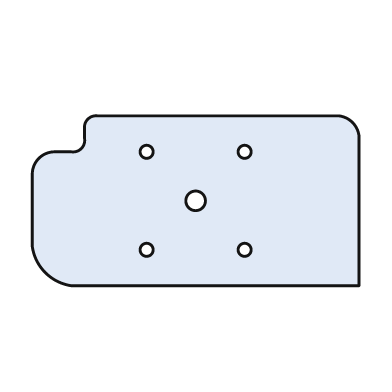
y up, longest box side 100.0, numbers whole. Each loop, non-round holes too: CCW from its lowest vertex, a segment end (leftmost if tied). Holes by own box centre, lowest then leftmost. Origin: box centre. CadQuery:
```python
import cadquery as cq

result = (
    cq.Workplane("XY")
    .moveTo(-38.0, -26.0)
    .lineTo(50.0, -26.0)
    .lineTo(50.0, 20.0)
    .threePointArc((48.0, 24.0), (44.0, 26.0))
    .lineTo(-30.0, 26.0)
    .threePointArc((-33.0, 25.0), (-34.0, 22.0))
    .lineTo(-34.0, 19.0)
    .threePointArc((-35.0, 16.0), (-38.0, 15.0))
    .lineTo(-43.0, 15.0)
    .threePointArc((-48.0, 13.0), (-50.0, 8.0))
    .lineTo(-50.0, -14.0)
    .threePointArc((-46.0, -22.0), (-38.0, -26.0))
    .close()
    .moveTo(-15.0, -15.0)
    .circle(2.0)
    .moveTo(15.0, -15.0)
    .circle(2.0)
    .moveTo(0.0, 0.0)
    .circle(3.0)
    .moveTo(-15.0, 15.0)
    .circle(2.0)
    .moveTo(15.0, 15.0)
    .circle(2.0)
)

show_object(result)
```